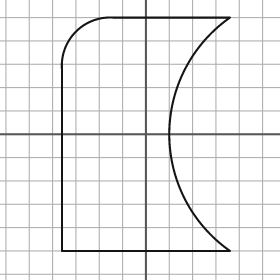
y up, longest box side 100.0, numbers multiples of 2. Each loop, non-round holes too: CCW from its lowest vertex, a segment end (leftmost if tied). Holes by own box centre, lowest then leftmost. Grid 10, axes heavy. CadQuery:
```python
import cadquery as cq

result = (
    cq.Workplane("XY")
    .moveTo(-36.0, -50.0)
    .lineTo(36.0, -50.0)
    .threePointArc((10.0, 0.0), (36.0, 50.0))
    .lineTo(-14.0, 50.0)
    .threePointArc((-30.0, 44.0), (-36.0, 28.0))
    .close()
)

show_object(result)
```